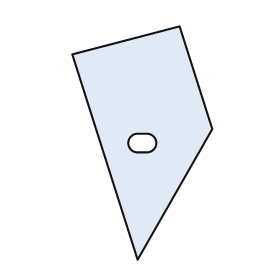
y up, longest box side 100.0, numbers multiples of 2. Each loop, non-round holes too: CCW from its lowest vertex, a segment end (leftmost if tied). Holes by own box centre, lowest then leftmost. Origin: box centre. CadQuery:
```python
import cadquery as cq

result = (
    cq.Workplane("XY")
    .moveTo(-2.0, -50.0)
    .lineTo(30.0, 6.0)
    .lineTo(16.0, 50.0)
    .lineTo(-30.0, 38.0)
    .close()
    .moveTo(-2.0, -4.0)
    .lineTo(2.0, -4.0)
    .threePointArc((6.0, 0.0), (2.0, 4.0))
    .lineTo(-2.0, 4.0)
    .threePointArc((-6.0, 0.0), (-2.0, -4.0))
    .close()
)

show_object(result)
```